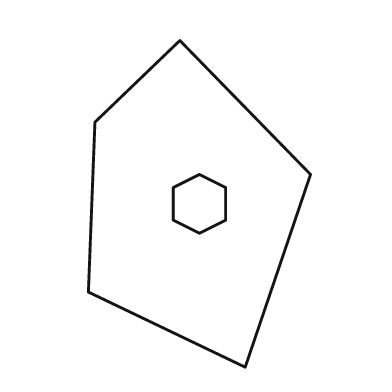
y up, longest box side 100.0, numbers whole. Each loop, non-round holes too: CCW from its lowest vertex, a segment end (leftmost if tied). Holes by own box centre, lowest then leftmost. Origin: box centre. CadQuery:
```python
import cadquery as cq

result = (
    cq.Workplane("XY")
    .moveTo(14.0, -50.0)
    .lineTo(34.0, 9.0)
    .lineTo(-6.0, 50.0)
    .lineTo(-32.0, 25.0)
    .lineTo(-34.0, -27.0)
    .close()
    .moveTo(0.0, -9.0)
    .lineTo(8.0, -5.0)
    .lineTo(8.0, 5.0)
    .lineTo(0.0, 9.0)
    .lineTo(-8.0, 5.0)
    .lineTo(-8.0, -5.0)
    .close()
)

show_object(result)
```